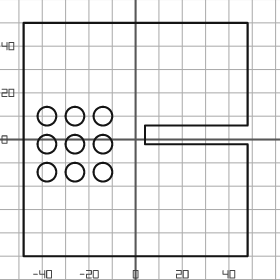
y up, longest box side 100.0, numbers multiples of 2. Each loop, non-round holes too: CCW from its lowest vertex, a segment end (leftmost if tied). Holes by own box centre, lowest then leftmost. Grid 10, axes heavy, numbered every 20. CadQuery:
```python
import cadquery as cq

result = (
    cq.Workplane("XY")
    .moveTo(-48.0, -50.0)
    .lineTo(48.0, -50.0)
    .lineTo(48.0, -2.0)
    .lineTo(4.0, -2.0)
    .lineTo(4.0, 6.0)
    .lineTo(48.0, 6.0)
    .lineTo(48.0, 50.0)
    .lineTo(-48.0, 50.0)
    .close()
    .moveTo(-38.0, -14.0)
    .circle(4.0)
    .moveTo(-26.0, -14.0)
    .circle(4.0)
    .moveTo(-14.0, -14.0)
    .circle(4.0)
    .moveTo(-38.0, -2.0)
    .circle(4.0)
    .moveTo(-26.0, -2.0)
    .circle(4.0)
    .moveTo(-14.0, -2.0)
    .circle(4.0)
    .moveTo(-38.0, 10.0)
    .circle(4.0)
    .moveTo(-26.0, 10.0)
    .circle(4.0)
    .moveTo(-14.0, 10.0)
    .circle(4.0)
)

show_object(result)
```